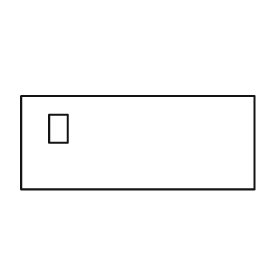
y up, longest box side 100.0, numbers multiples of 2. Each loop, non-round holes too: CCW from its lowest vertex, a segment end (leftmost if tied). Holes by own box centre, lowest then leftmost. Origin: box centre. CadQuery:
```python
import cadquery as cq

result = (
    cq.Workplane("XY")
    .moveTo(-50.0, -20.0)
    .lineTo(50.0, -20.0)
    .lineTo(50.0, 20.0)
    .lineTo(-50.0, 20.0)
    .close()
    .moveTo(-38.0, 0.0)
    .lineTo(-30.0, 0.0)
    .lineTo(-30.0, 12.0)
    .lineTo(-38.0, 12.0)
    .close()
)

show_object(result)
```